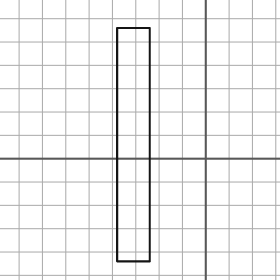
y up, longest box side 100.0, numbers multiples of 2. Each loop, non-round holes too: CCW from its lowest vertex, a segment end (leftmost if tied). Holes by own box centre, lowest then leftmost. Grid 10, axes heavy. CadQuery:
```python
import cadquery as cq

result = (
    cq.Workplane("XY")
    .moveTo(-38.0, -44.0)
    .lineTo(-24.0, -44.0)
    .lineTo(-24.0, 56.0)
    .lineTo(-38.0, 56.0)
    .close()
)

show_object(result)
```